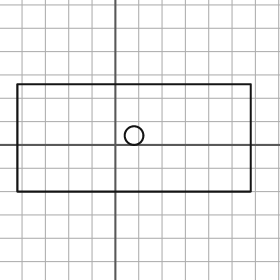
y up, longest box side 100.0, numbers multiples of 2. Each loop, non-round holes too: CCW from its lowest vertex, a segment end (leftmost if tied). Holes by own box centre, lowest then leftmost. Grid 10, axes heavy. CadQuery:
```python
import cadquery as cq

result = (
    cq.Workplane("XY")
    .moveTo(-42.0, -20.0)
    .lineTo(58.0, -20.0)
    .lineTo(58.0, 26.0)
    .lineTo(-42.0, 26.0)
    .close()
    .moveTo(8.0, 4.0)
    .circle(4.0)
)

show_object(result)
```